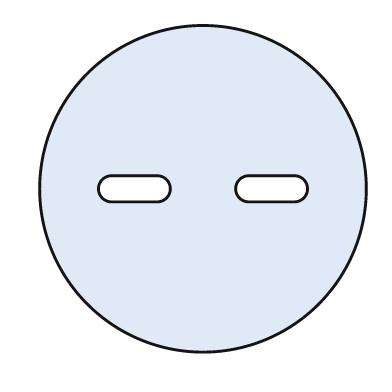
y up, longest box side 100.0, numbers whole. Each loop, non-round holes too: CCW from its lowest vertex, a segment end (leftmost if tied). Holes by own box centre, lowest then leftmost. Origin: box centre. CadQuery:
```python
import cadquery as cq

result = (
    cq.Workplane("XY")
    .moveTo(0.0, 0.0)
    .circle(50.0)
    .moveTo(-28.0, -4.0)
    .lineTo(-14.0, -4.0)
    .threePointArc((-10.0, 0.0), (-14.0, 4.0))
    .lineTo(-28.0, 4.0)
    .threePointArc((-32.0, 0.0), (-28.0, -4.0))
    .close()
    .moveTo(14.0, -4.0)
    .lineTo(28.0, -4.0)
    .threePointArc((32.0, 0.0), (28.0, 4.0))
    .lineTo(14.0, 4.0)
    .threePointArc((10.0, 0.0), (14.0, -4.0))
    .close()
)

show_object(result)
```